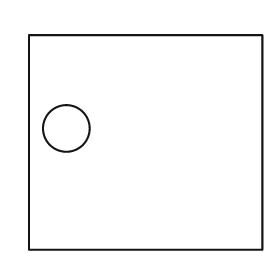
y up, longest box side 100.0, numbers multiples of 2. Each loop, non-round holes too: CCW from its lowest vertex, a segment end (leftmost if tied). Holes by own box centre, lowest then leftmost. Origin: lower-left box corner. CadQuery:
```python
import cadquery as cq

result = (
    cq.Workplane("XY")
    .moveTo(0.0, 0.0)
    .lineTo(100.0, 0.0)
    .lineTo(100.0, 92.0)
    .lineTo(0.0, 92.0)
    .close()
    .moveTo(16.0, 52.0)
    .circle(10.0)
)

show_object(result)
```